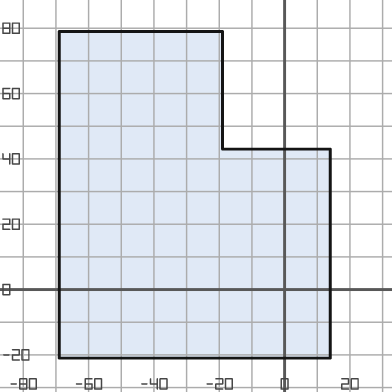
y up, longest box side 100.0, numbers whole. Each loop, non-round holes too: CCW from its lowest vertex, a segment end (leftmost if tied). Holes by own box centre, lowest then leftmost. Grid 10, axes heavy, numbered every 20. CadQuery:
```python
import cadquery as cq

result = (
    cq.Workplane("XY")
    .moveTo(-69.0, -21.0)
    .lineTo(14.0, -21.0)
    .lineTo(14.0, 43.0)
    .lineTo(-19.0, 43.0)
    .lineTo(-19.0, 79.0)
    .lineTo(-69.0, 79.0)
    .close()
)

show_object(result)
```